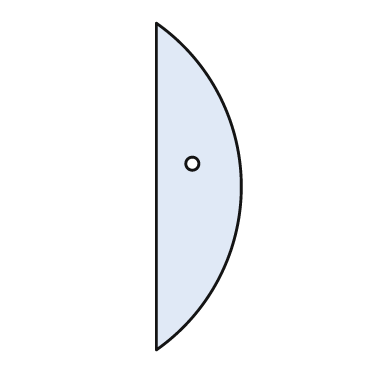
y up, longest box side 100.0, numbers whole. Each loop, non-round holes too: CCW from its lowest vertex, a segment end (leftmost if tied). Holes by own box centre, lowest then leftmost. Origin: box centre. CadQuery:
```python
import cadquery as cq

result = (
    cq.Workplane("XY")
    .moveTo(-13.0, -50.0)
    .threePointArc((13.0, 0.0), (-13.0, 50.0))
    .close()
    .moveTo(-2.0, 7.0)
    .circle(2.0)
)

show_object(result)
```